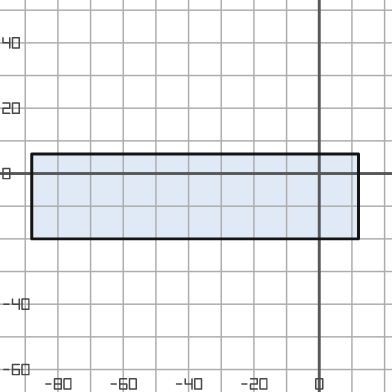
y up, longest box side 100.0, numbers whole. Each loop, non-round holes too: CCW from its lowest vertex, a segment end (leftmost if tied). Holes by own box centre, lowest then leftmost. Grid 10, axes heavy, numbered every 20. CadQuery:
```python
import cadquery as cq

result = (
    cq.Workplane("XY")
    .moveTo(-88.0, -20.0)
    .lineTo(12.0, -20.0)
    .lineTo(12.0, 6.0)
    .lineTo(-88.0, 6.0)
    .close()
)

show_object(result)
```